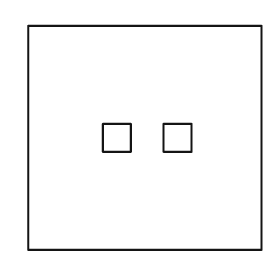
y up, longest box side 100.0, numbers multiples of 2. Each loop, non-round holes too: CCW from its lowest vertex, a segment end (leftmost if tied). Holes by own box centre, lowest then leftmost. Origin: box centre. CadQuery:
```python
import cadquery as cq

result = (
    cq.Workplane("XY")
    .moveTo(-50.0, -48.0)
    .lineTo(50.0, -48.0)
    .lineTo(50.0, 48.0)
    .lineTo(-50.0, 48.0)
    .close()
    .moveTo(-18.0, -6.0)
    .lineTo(-6.0, -6.0)
    .lineTo(-6.0, 6.0)
    .lineTo(-18.0, 6.0)
    .close()
    .moveTo(8.0, -6.0)
    .lineTo(20.0, -6.0)
    .lineTo(20.0, 6.0)
    .lineTo(8.0, 6.0)
    .close()
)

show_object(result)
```